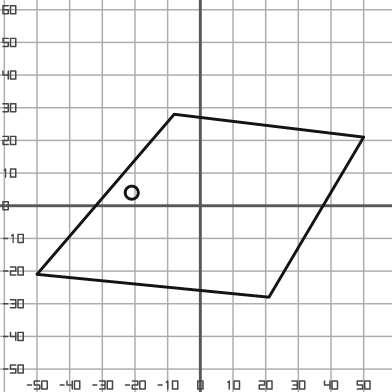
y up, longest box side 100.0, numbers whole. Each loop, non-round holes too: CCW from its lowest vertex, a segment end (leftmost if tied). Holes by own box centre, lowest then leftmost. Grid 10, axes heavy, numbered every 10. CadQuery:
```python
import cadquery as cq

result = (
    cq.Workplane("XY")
    .moveTo(21.0, -28.0)
    .lineTo(50.0, 21.0)
    .lineTo(-8.0, 28.0)
    .lineTo(-50.0, -21.0)
    .close()
    .moveTo(-21.0, 4.0)
    .circle(2.0)
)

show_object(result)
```